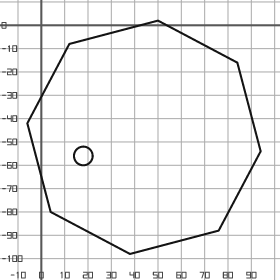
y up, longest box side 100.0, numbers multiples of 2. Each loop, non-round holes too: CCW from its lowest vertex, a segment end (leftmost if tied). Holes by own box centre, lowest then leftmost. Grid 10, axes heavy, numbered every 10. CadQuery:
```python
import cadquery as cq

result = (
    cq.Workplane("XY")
    .moveTo(38.0, -98.0)
    .lineTo(76.0, -88.0)
    .lineTo(94.0, -54.0)
    .lineTo(84.0, -16.0)
    .lineTo(50.0, 2.0)
    .lineTo(12.0, -8.0)
    .lineTo(-6.0, -42.0)
    .lineTo(4.0, -80.0)
    .close()
    .moveTo(18.0, -56.0)
    .circle(4.0)
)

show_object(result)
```